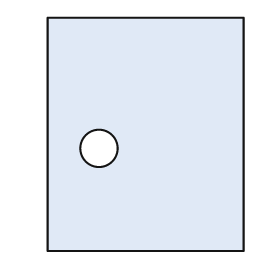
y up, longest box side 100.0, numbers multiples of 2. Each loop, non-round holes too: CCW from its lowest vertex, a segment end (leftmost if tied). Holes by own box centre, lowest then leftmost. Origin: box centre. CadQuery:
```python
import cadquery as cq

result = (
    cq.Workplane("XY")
    .moveTo(-42.0, -50.0)
    .lineTo(42.0, -50.0)
    .lineTo(42.0, 50.0)
    .lineTo(-42.0, 50.0)
    .close()
    .moveTo(-20.0, -6.0)
    .circle(8.0)
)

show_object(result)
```